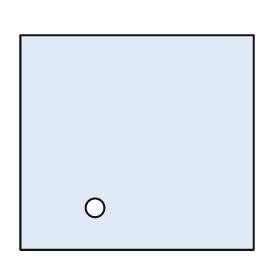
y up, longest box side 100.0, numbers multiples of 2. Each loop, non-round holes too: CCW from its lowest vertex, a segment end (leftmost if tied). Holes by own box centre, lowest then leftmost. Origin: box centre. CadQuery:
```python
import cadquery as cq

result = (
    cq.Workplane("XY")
    .moveTo(-50.0, -46.0)
    .lineTo(50.0, -46.0)
    .lineTo(50.0, 46.0)
    .lineTo(-50.0, 46.0)
    .close()
    .moveTo(-18.0, -28.0)
    .circle(4.0)
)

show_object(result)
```